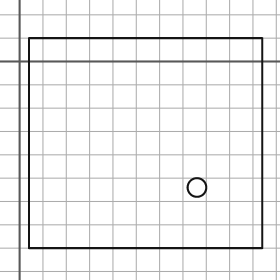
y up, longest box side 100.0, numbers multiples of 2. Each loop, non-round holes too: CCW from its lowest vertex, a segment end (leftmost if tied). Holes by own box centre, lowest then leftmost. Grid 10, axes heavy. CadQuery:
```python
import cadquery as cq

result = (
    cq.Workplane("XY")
    .moveTo(4.0, -80.0)
    .lineTo(104.0, -80.0)
    .lineTo(104.0, 10.0)
    .lineTo(4.0, 10.0)
    .close()
    .moveTo(76.0, -54.0)
    .circle(4.0)
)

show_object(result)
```